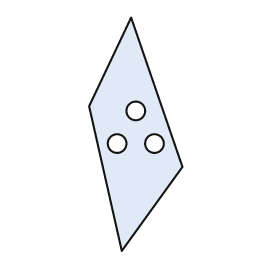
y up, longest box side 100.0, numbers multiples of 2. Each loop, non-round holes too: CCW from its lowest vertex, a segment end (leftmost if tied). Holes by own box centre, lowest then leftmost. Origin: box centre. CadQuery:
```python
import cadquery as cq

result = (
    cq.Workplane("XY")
    .moveTo(-6.0, -50.0)
    .lineTo(20.0, -14.0)
    .lineTo(-2.0, 50.0)
    .lineTo(-20.0, 12.0)
    .close()
    .moveTo(-8.0, -4.0)
    .circle(4.0)
    .moveTo(8.0, -4.0)
    .circle(4.0)
    .moveTo(0.0, 10.0)
    .circle(4.0)
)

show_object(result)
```